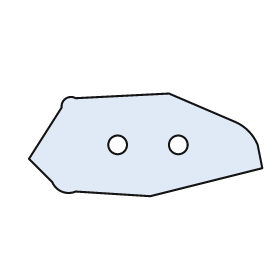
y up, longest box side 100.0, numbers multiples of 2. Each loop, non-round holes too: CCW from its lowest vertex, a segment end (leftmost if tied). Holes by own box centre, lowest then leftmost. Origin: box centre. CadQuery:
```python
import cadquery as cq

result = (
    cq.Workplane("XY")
    .moveTo(2.0, -22.0)
    .lineTo(50.0, -10.0)
    .lineTo(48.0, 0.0)
    .threePointArc((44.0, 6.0), (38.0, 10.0))
    .lineTo(10.0, 22.0)
    .lineTo(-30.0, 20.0)
    .threePointArc((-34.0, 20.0), (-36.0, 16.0))
    .lineTo(-50.0, -6.0)
    .lineTo(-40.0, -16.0)
    .threePointArc((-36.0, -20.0), (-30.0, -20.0))
    .close()
    .moveTo(-12.0, 0.0)
    .circle(4.0)
    .moveTo(14.0, 0.0)
    .circle(4.0)
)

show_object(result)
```